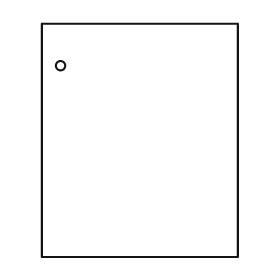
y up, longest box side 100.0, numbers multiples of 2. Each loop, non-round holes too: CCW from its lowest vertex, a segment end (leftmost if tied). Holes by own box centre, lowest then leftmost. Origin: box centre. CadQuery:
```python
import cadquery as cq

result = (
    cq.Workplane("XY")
    .moveTo(-42.0, -50.0)
    .lineTo(42.0, -50.0)
    .lineTo(42.0, 50.0)
    .lineTo(-42.0, 50.0)
    .close()
    .moveTo(-34.0, 32.0)
    .circle(2.0)
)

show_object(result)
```